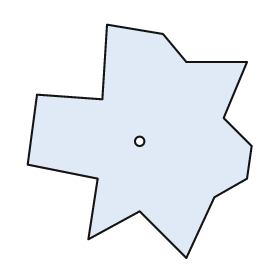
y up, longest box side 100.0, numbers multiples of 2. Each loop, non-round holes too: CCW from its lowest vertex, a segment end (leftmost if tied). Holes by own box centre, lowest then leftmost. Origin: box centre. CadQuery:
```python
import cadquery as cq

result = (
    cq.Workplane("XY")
    .moveTo(20.0, -50.0)
    .lineTo(32.0, -24.0)
    .lineTo(46.0, -16.0)
    .lineTo(48.0, -2.0)
    .lineTo(36.0, 10.0)
    .lineTo(46.0, 34.0)
    .lineTo(20.0, 34.0)
    .lineTo(10.0, 46.0)
    .lineTo(-14.0, 50.0)
    .lineTo(-16.0, 18.0)
    .lineTo(-44.0, 20.0)
    .lineTo(-48.0, -10.0)
    .lineTo(-18.0, -16.0)
    .lineTo(-22.0, -42.0)
    .lineTo(0.0, -30.0)
    .close()
    .moveTo(0.0, 0.0)
    .circle(2.0)
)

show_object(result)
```